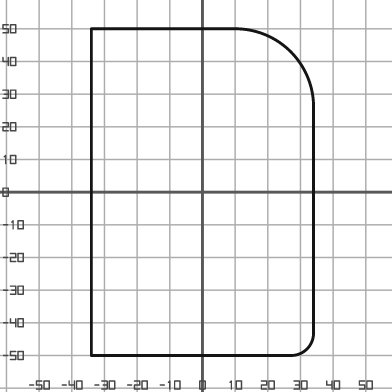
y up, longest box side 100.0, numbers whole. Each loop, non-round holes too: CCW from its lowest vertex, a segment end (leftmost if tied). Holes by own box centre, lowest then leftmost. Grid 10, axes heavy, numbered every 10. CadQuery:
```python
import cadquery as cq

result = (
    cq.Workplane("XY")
    .moveTo(-34.0, -50.0)
    .lineTo(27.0, -50.0)
    .threePointArc((32.0, -48.0), (34.0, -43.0))
    .lineTo(34.0, 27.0)
    .threePointArc((27.0, 43.0), (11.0, 50.0))
    .lineTo(-34.0, 50.0)
    .close()
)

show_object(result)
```